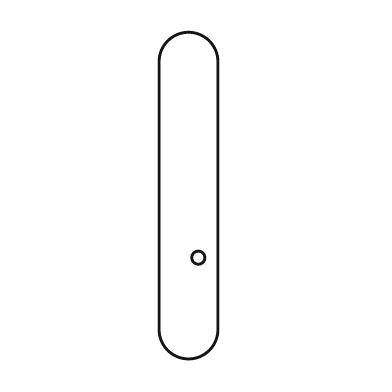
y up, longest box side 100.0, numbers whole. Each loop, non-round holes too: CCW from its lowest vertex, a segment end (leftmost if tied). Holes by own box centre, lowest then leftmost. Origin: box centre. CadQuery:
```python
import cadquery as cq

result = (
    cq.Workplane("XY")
    .moveTo(-9.0, -41.0)
    .threePointArc((0.0, -50.0), (9.0, -41.0))
    .lineTo(9.0, 41.0)
    .threePointArc((0.0, 50.0), (-9.0, 41.0))
    .close()
    .moveTo(3.0, -19.0)
    .circle(2.0)
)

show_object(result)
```